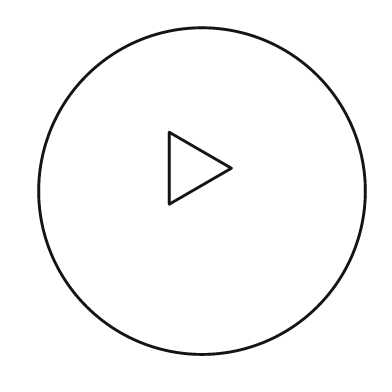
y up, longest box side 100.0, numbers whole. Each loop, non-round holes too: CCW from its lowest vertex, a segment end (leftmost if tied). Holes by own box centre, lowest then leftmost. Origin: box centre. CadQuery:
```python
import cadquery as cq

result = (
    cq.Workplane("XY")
    .moveTo(0.0, 0.0)
    .circle(50.0)
    .moveTo(-10.0, -4.0)
    .lineTo(9.0, 7.0)
    .lineTo(-10.0, 18.0)
    .close()
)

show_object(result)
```